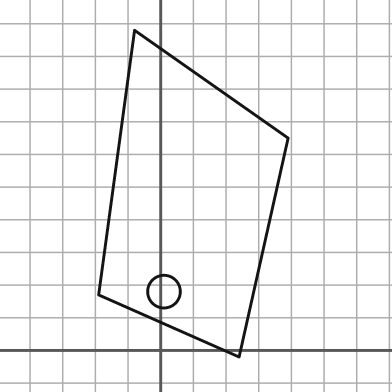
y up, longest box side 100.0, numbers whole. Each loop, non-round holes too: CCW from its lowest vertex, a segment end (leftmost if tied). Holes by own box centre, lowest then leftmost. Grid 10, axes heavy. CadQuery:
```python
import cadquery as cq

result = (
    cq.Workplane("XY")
    .moveTo(24.0, -2.0)
    .lineTo(39.0, 65.0)
    .lineTo(-8.0, 98.0)
    .lineTo(-19.0, 17.0)
    .close()
    .moveTo(1.0, 18.0)
    .circle(5.0)
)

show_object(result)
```